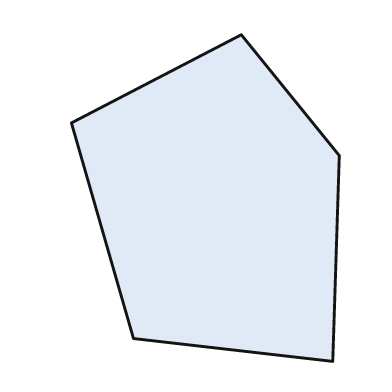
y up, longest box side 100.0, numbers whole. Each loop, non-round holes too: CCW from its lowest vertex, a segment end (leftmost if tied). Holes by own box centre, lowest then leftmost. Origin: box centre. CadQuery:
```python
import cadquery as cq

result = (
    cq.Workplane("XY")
    .moveTo(39.0, -50.0)
    .lineTo(41.0, 13.0)
    .lineTo(11.0, 50.0)
    .lineTo(-41.0, 23.0)
    .lineTo(-22.0, -43.0)
    .close()
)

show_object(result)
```